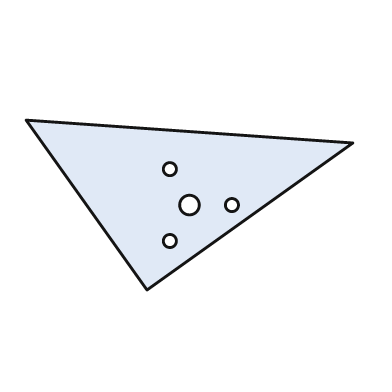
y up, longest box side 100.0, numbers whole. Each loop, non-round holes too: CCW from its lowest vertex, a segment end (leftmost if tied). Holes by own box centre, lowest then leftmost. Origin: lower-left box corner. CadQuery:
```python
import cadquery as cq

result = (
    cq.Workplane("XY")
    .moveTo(37.0, 0.0)
    .lineTo(100.0, 45.0)
    .lineTo(0.0, 52.0)
    .close()
    .moveTo(44.0, 15.0)
    .circle(2.0)
    .moveTo(50.0, 26.0)
    .circle(3.0)
    .moveTo(63.0, 26.0)
    .circle(2.0)
    .moveTo(44.0, 37.0)
    .circle(2.0)
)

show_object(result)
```